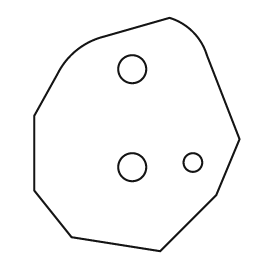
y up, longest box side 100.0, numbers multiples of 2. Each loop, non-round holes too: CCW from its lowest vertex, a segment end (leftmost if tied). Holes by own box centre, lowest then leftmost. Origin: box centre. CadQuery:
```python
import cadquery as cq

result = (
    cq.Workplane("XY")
    .moveTo(10.0, -50.0)
    .lineTo(34.0, -26.0)
    .lineTo(44.0, -2.0)
    .lineTo(30.0, 34.0)
    .threePointArc((24.0, 44.0), (14.0, 50.0))
    .lineTo(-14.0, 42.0)
    .threePointArc((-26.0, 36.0), (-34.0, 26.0))
    .lineTo(-44.0, 8.0)
    .lineTo(-44.0, -24.0)
    .lineTo(-28.0, -44.0)
    .close()
    .moveTo(-2.0, -14.0)
    .circle(6.0)
    .moveTo(24.0, -12.0)
    .circle(4.0)
    .moveTo(-2.0, 28.0)
    .circle(6.0)
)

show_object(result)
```